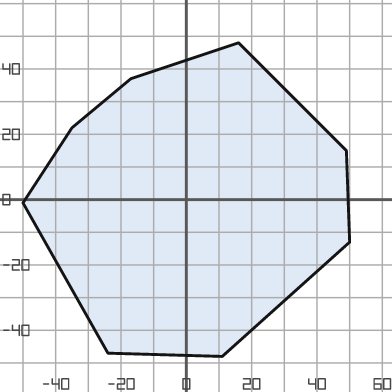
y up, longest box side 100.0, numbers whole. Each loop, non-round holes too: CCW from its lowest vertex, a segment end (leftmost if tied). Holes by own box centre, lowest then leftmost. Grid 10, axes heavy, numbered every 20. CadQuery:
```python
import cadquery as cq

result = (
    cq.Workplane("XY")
    .moveTo(11.0, -48.0)
    .lineTo(50.0, -13.0)
    .lineTo(49.0, 15.0)
    .lineTo(16.0, 48.0)
    .lineTo(-17.0, 37.0)
    .lineTo(-35.0, 22.0)
    .lineTo(-50.0, -1.0)
    .lineTo(-24.0, -47.0)
    .close()
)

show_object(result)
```